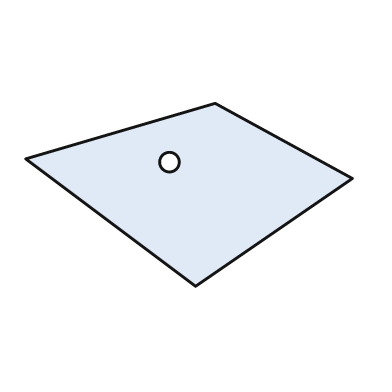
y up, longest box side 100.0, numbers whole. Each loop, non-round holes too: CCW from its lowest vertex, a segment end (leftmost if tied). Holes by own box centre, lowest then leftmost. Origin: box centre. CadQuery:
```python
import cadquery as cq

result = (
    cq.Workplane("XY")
    .moveTo(2.0, -28.0)
    .lineTo(50.0, 5.0)
    .lineTo(8.0, 28.0)
    .lineTo(-50.0, 11.0)
    .close()
    .moveTo(-6.0, 10.0)
    .circle(3.0)
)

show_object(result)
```